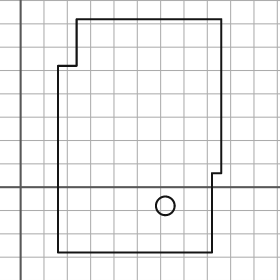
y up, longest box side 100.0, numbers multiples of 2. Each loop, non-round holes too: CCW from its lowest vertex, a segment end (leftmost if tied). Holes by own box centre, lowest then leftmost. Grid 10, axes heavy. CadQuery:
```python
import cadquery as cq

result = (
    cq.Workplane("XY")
    .moveTo(16.0, -28.0)
    .lineTo(82.0, -28.0)
    .lineTo(82.0, 6.0)
    .lineTo(86.0, 6.0)
    .lineTo(86.0, 72.0)
    .lineTo(24.0, 72.0)
    .lineTo(24.0, 52.0)
    .lineTo(16.0, 52.0)
    .close()
    .moveTo(62.0, -8.0)
    .circle(4.0)
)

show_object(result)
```